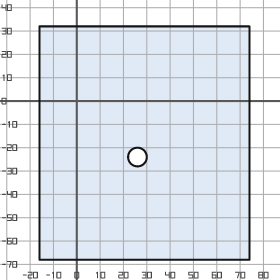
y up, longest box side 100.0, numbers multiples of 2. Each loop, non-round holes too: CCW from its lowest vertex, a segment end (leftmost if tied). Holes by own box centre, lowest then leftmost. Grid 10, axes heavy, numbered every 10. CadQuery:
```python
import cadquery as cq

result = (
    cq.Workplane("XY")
    .moveTo(-16.0, -68.0)
    .lineTo(74.0, -68.0)
    .lineTo(74.0, 32.0)
    .lineTo(-16.0, 32.0)
    .close()
    .moveTo(26.0, -24.0)
    .circle(4.0)
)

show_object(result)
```